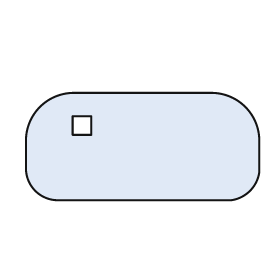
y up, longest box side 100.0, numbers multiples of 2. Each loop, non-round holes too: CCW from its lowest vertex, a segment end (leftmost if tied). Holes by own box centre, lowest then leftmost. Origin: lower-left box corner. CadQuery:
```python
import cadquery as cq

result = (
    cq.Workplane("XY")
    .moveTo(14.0, 0.0)
    .lineTo(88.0, 0.0)
    .threePointArc((96.0, 4.0), (100.0, 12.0))
    .lineTo(100.0, 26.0)
    .threePointArc((94.0, 40.0), (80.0, 46.0))
    .lineTo(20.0, 46.0)
    .threePointArc((6.0, 40.0), (0.0, 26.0))
    .lineTo(0.0, 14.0)
    .threePointArc((4.0, 4.0), (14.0, 0.0))
    .close()
    .moveTo(20.0, 28.0)
    .lineTo(28.0, 28.0)
    .lineTo(28.0, 36.0)
    .lineTo(20.0, 36.0)
    .close()
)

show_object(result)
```